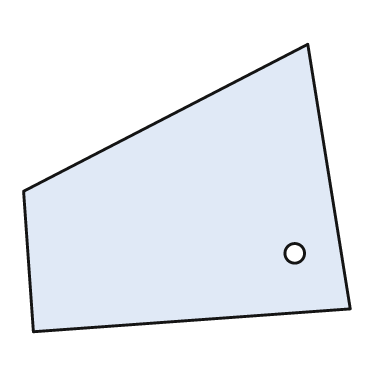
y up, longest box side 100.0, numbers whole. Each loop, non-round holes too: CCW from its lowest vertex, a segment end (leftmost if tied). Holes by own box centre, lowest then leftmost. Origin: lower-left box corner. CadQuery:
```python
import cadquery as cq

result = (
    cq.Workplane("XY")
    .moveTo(3.0, 0.0)
    .lineTo(100.0, 7.0)
    .lineTo(87.0, 88.0)
    .lineTo(0.0, 43.0)
    .close()
    .moveTo(83.0, 24.0)
    .circle(3.0)
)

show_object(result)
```